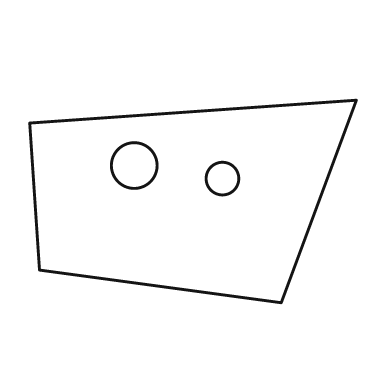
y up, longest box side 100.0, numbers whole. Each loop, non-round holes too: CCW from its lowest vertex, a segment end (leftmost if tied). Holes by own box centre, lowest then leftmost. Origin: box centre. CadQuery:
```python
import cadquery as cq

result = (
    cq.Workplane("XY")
    .moveTo(27.0, -31.0)
    .lineTo(50.0, 31.0)
    .lineTo(-50.0, 24.0)
    .lineTo(-47.0, -21.0)
    .close()
    .moveTo(9.0, 7.0)
    .circle(5.0)
    .moveTo(-18.0, 11.0)
    .circle(7.0)
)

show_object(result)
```